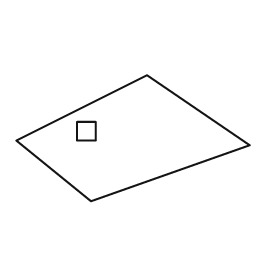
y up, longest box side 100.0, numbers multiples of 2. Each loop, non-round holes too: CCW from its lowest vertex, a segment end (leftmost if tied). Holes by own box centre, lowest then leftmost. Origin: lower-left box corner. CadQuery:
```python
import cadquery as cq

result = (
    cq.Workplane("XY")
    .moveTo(32.0, 0.0)
    .lineTo(100.0, 24.0)
    .lineTo(56.0, 54.0)
    .lineTo(0.0, 26.0)
    .close()
    .moveTo(26.0, 26.0)
    .lineTo(34.0, 26.0)
    .lineTo(34.0, 34.0)
    .lineTo(26.0, 34.0)
    .close()
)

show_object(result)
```